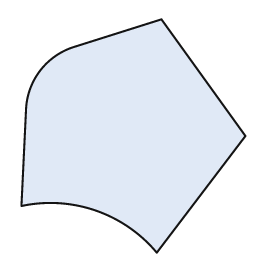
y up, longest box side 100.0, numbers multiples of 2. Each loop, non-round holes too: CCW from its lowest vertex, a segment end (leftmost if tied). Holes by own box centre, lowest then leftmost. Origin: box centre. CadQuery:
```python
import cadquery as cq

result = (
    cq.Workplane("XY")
    .moveTo(10.0, -50.0)
    .lineTo(48.0, 0.0)
    .lineTo(12.0, 50.0)
    .lineTo(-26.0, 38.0)
    .threePointArc((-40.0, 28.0), (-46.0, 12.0))
    .lineTo(-48.0, -30.0)
    .threePointArc((-16.0, -32.0), (10.0, -50.0))
    .close()
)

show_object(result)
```